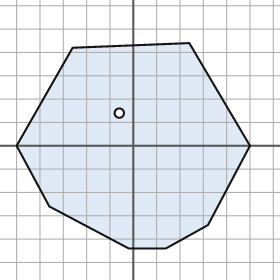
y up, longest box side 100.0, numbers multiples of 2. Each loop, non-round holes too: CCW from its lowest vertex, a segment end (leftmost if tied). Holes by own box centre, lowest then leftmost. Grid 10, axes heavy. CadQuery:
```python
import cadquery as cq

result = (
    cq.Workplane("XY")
    .moveTo(-2.0, -44.0)
    .lineTo(14.0, -44.0)
    .lineTo(32.0, -34.0)
    .lineTo(50.0, 0.0)
    .lineTo(24.0, 44.0)
    .lineTo(-26.0, 42.0)
    .lineTo(-50.0, 0.0)
    .lineTo(-36.0, -26.0)
    .close()
    .moveTo(-6.0, 14.0)
    .circle(2.0)
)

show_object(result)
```